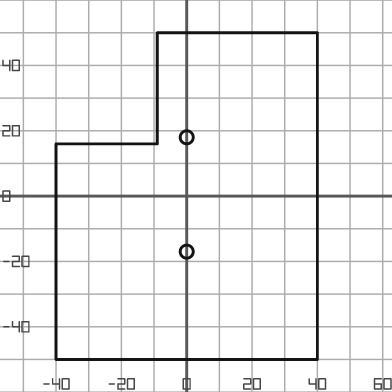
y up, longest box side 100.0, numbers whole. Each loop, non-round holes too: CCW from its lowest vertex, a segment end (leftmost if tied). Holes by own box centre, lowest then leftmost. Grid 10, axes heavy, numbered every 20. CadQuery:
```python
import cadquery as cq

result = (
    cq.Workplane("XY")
    .moveTo(-40.0, -50.0)
    .lineTo(40.0, -50.0)
    .lineTo(40.0, 50.0)
    .lineTo(-9.0, 50.0)
    .lineTo(-9.0, 16.0)
    .lineTo(-40.0, 16.0)
    .close()
    .moveTo(0.0, -17.0)
    .circle(2.0)
    .moveTo(0.0, 18.0)
    .circle(2.0)
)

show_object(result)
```